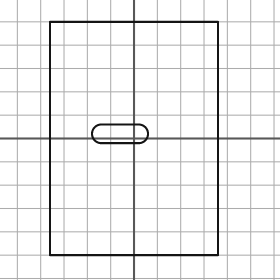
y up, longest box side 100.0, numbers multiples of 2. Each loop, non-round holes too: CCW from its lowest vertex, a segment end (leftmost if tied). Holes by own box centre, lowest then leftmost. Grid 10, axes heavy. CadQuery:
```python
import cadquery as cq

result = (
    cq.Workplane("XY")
    .moveTo(-36.0, -50.0)
    .lineTo(36.0, -50.0)
    .lineTo(36.0, 50.0)
    .lineTo(-36.0, 50.0)
    .close()
    .moveTo(-14.0, -2.0)
    .lineTo(2.0, -2.0)
    .threePointArc((6.0, 2.0), (2.0, 6.0))
    .lineTo(-14.0, 6.0)
    .threePointArc((-18.0, 2.0), (-14.0, -2.0))
    .close()
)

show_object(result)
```